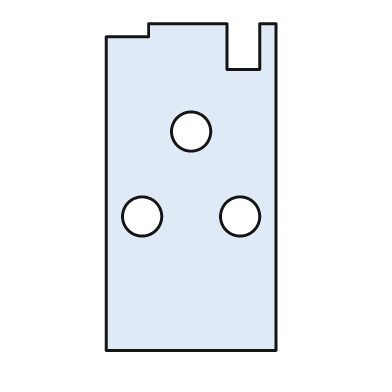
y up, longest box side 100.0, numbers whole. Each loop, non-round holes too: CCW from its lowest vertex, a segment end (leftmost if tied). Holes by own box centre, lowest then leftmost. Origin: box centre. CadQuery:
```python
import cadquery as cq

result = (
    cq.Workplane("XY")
    .moveTo(-26.0, -50.0)
    .lineTo(26.0, -50.0)
    .lineTo(26.0, 50.0)
    .lineTo(21.0, 50.0)
    .lineTo(21.0, 36.0)
    .lineTo(11.0, 36.0)
    .lineTo(11.0, 50.0)
    .lineTo(-13.0, 50.0)
    .lineTo(-13.0, 46.0)
    .lineTo(-26.0, 46.0)
    .close()
    .moveTo(-15.0, -9.0)
    .circle(6.0)
    .moveTo(15.0, -9.0)
    .circle(6.0)
    .moveTo(0.0, 17.0)
    .circle(6.0)
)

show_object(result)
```